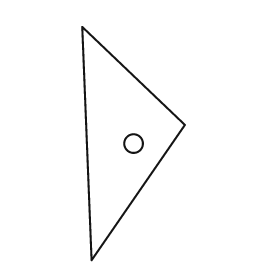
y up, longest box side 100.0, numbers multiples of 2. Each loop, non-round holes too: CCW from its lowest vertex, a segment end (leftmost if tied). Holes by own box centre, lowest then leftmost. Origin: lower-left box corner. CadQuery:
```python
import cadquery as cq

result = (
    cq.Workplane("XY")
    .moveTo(4.0, 0.0)
    .lineTo(44.0, 58.0)
    .lineTo(0.0, 100.0)
    .close()
    .moveTo(22.0, 50.0)
    .circle(4.0)
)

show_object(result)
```